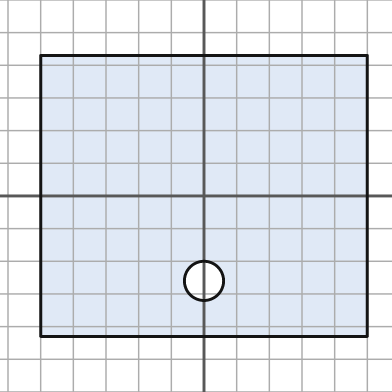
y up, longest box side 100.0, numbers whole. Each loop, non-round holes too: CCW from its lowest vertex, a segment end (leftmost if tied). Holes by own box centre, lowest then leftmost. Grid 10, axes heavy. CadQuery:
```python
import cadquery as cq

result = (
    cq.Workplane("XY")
    .moveTo(-50.0, -43.0)
    .lineTo(50.0, -43.0)
    .lineTo(50.0, 43.0)
    .lineTo(-50.0, 43.0)
    .close()
    .moveTo(0.0, -26.0)
    .circle(6.0)
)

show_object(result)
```